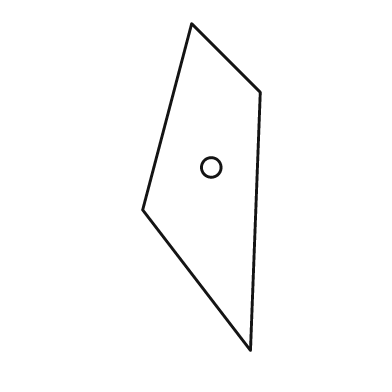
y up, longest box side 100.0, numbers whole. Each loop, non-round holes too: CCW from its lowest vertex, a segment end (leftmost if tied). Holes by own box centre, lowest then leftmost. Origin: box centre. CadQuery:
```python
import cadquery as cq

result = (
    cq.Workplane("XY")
    .moveTo(15.0, -50.0)
    .lineTo(18.0, 29.0)
    .lineTo(-3.0, 50.0)
    .lineTo(-18.0, -7.0)
    .close()
    .moveTo(3.0, 6.0)
    .circle(3.0)
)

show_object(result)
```